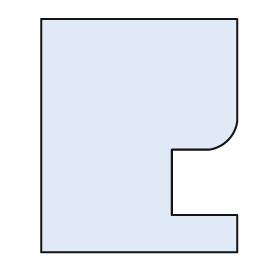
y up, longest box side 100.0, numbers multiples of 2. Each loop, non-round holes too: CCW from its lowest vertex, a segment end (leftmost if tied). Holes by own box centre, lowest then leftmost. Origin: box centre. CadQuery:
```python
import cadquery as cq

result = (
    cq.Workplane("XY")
    .moveTo(-42.0, -50.0)
    .lineTo(42.0, -50.0)
    .lineTo(42.0, -34.0)
    .lineTo(14.0, -34.0)
    .lineTo(14.0, -6.0)
    .lineTo(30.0, -6.0)
    .threePointArc((38.0, -2.0), (42.0, 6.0))
    .lineTo(42.0, 50.0)
    .lineTo(-42.0, 50.0)
    .close()
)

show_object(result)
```